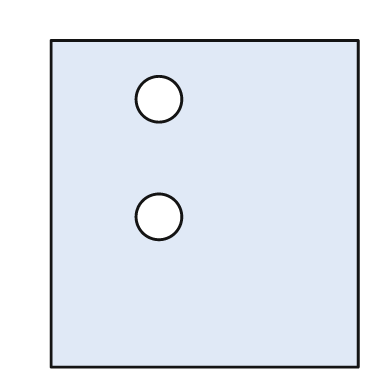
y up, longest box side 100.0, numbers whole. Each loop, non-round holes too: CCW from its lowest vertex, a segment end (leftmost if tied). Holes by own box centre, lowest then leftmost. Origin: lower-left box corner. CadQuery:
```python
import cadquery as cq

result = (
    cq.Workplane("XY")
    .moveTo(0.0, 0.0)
    .lineTo(94.0, 0.0)
    .lineTo(94.0, 100.0)
    .lineTo(0.0, 100.0)
    .close()
    .moveTo(33.0, 46.0)
    .circle(7.0)
    .moveTo(33.0, 82.0)
    .circle(7.0)
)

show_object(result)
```